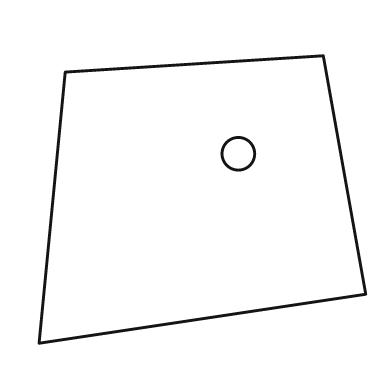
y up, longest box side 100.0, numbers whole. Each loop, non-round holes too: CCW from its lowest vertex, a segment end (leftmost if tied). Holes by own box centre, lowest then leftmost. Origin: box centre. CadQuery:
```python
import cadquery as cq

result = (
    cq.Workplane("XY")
    .moveTo(-50.0, -44.0)
    .lineTo(50.0, -29.0)
    .lineTo(37.0, 44.0)
    .lineTo(-42.0, 39.0)
    .close()
    .moveTo(11.0, 14.0)
    .circle(5.0)
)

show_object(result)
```